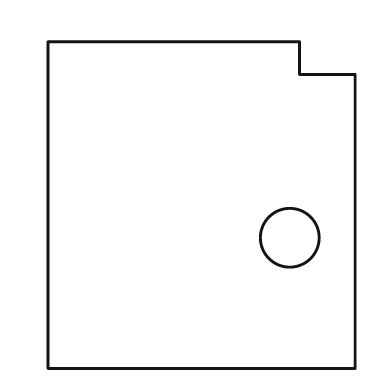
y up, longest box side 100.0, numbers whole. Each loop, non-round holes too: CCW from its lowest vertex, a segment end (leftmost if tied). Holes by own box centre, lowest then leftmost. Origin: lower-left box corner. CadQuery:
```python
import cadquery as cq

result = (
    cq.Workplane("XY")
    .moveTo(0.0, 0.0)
    .lineTo(94.0, 0.0)
    .lineTo(94.0, 90.0)
    .lineTo(77.0, 90.0)
    .lineTo(77.0, 100.0)
    .lineTo(0.0, 100.0)
    .close()
    .moveTo(74.0, 40.0)
    .circle(9.0)
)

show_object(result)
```